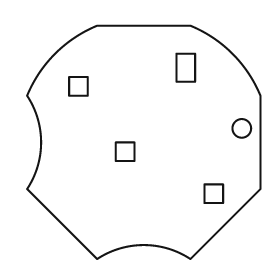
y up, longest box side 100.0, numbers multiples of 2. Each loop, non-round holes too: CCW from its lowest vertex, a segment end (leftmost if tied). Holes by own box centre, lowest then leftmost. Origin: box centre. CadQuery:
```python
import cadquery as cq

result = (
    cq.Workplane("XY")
    .moveTo(-20.0, -50.0)
    .threePointArc((0.0, -44.0), (20.0, -50.0))
    .lineTo(50.0, -20.0)
    .lineTo(50.0, 20.0)
    .threePointArc((38.0, 38.0), (20.0, 50.0))
    .lineTo(-20.0, 50.0)
    .threePointArc((-38.0, 38.0), (-50.0, 20.0))
    .threePointArc((-44.0, 0.0), (-50.0, -20.0))
    .close()
    .moveTo(26.0, -26.0)
    .lineTo(34.0, -26.0)
    .lineTo(34.0, -18.0)
    .lineTo(26.0, -18.0)
    .close()
    .moveTo(-12.0, -8.0)
    .lineTo(-4.0, -8.0)
    .lineTo(-4.0, 0.0)
    .lineTo(-12.0, 0.0)
    .close()
    .moveTo(42.0, 6.0)
    .circle(4.0)
    .moveTo(-32.0, 20.0)
    .lineTo(-24.0, 20.0)
    .lineTo(-24.0, 28.0)
    .lineTo(-32.0, 28.0)
    .close()
    .moveTo(14.0, 26.0)
    .lineTo(22.0, 26.0)
    .lineTo(22.0, 38.0)
    .lineTo(14.0, 38.0)
    .close()
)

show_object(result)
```